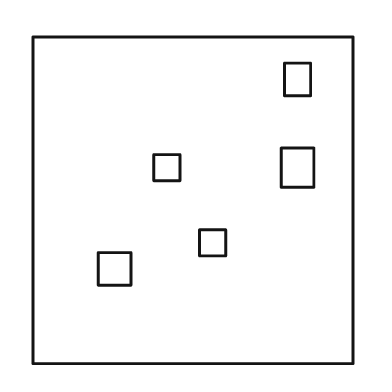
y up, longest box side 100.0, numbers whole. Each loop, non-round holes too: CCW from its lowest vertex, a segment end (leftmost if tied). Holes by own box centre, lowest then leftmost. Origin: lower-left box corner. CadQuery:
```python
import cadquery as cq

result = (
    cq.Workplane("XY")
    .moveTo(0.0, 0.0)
    .lineTo(98.0, 0.0)
    .lineTo(98.0, 100.0)
    .lineTo(0.0, 100.0)
    .close()
    .moveTo(20.0, 24.0)
    .lineTo(30.0, 24.0)
    .lineTo(30.0, 34.0)
    .lineTo(20.0, 34.0)
    .close()
    .moveTo(51.0, 33.0)
    .lineTo(59.0, 33.0)
    .lineTo(59.0, 41.0)
    .lineTo(51.0, 41.0)
    .close()
    .moveTo(37.0, 56.0)
    .lineTo(45.0, 56.0)
    .lineTo(45.0, 64.0)
    .lineTo(37.0, 64.0)
    .close()
    .moveTo(76.0, 54.0)
    .lineTo(86.0, 54.0)
    .lineTo(86.0, 66.0)
    .lineTo(76.0, 66.0)
    .close()
    .moveTo(77.0, 82.0)
    .lineTo(85.0, 82.0)
    .lineTo(85.0, 92.0)
    .lineTo(77.0, 92.0)
    .close()
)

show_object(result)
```